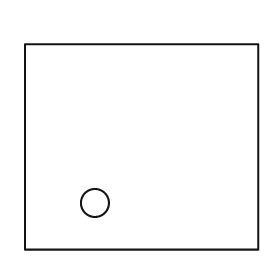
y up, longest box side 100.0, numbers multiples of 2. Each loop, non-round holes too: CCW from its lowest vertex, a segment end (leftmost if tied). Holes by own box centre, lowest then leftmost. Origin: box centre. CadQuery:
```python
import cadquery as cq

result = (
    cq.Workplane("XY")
    .moveTo(-50.0, -44.0)
    .lineTo(50.0, -44.0)
    .lineTo(50.0, 44.0)
    .lineTo(-50.0, 44.0)
    .close()
    .moveTo(-20.0, -24.0)
    .circle(6.0)
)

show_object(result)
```